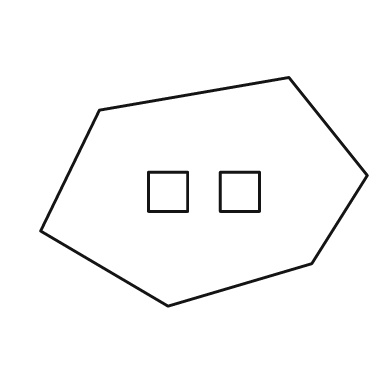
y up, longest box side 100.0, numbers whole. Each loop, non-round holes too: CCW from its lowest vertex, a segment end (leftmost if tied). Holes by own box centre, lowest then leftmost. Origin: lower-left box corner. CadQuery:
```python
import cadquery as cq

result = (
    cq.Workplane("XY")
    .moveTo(39.0, 0.0)
    .lineTo(83.0, 13.0)
    .lineTo(100.0, 40.0)
    .lineTo(76.0, 70.0)
    .lineTo(18.0, 60.0)
    .lineTo(0.0, 23.0)
    .close()
    .moveTo(33.0, 29.0)
    .lineTo(45.0, 29.0)
    .lineTo(45.0, 41.0)
    .lineTo(33.0, 41.0)
    .close()
    .moveTo(55.0, 29.0)
    .lineTo(67.0, 29.0)
    .lineTo(67.0, 41.0)
    .lineTo(55.0, 41.0)
    .close()
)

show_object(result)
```